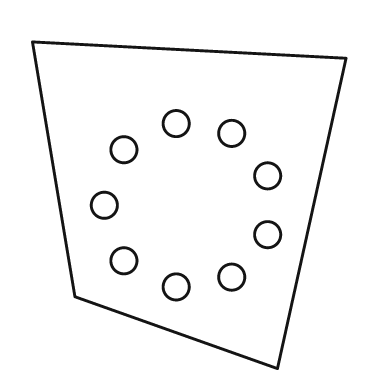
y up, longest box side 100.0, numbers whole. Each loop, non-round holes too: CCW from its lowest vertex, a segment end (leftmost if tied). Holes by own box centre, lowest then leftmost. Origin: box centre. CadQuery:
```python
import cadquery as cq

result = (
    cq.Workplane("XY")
    .moveTo(27.0, -50.0)
    .lineTo(48.0, 45.0)
    .lineTo(-48.0, 50.0)
    .lineTo(-35.0, -28.0)
    .close()
    .moveTo(-4.0, -25.0)
    .circle(4.0)
    .moveTo(13.0, -22.0)
    .circle(4.0)
    .moveTo(-20.0, -17.0)
    .circle(4.0)
    .moveTo(24.0, -9.0)
    .circle(4.0)
    .moveTo(-26.0, 0.0)
    .circle(4.0)
    .moveTo(24.0, 9.0)
    .circle(4.0)
    .moveTo(-20.0, 17.0)
    .circle(4.0)
    .moveTo(13.0, 22.0)
    .circle(4.0)
    .moveTo(-4.0, 25.0)
    .circle(4.0)
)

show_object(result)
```